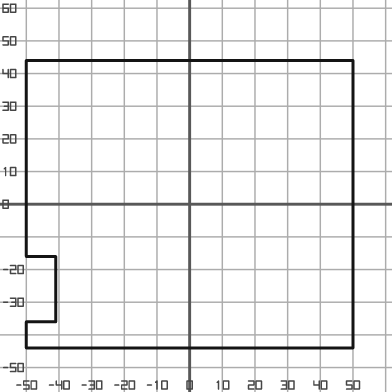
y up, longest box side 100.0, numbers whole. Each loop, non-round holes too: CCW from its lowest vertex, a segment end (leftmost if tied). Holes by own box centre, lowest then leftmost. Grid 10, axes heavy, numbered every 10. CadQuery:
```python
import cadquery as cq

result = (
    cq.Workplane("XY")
    .moveTo(-50.0, -44.0)
    .lineTo(50.0, -44.0)
    .lineTo(50.0, 44.0)
    .lineTo(-50.0, 44.0)
    .lineTo(-50.0, -16.0)
    .lineTo(-41.0, -16.0)
    .lineTo(-41.0, -36.0)
    .lineTo(-50.0, -36.0)
    .close()
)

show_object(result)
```